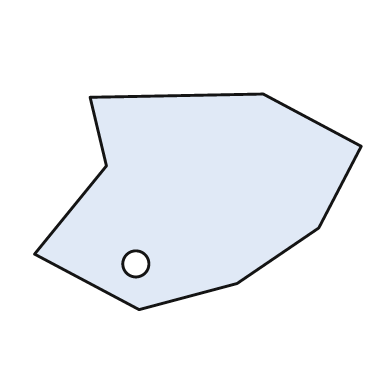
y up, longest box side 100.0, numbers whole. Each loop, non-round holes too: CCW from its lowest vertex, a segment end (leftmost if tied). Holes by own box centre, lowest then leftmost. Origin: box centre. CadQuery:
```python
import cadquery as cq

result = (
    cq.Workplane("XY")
    .moveTo(-18.0, -33.0)
    .lineTo(12.0, -25.0)
    .lineTo(37.0, -8.0)
    .lineTo(50.0, 17.0)
    .lineTo(20.0, 33.0)
    .lineTo(-33.0, 32.0)
    .lineTo(-28.0, 11.0)
    .lineTo(-50.0, -16.0)
    .close()
    .moveTo(-19.0, -19.0)
    .circle(4.0)
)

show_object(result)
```